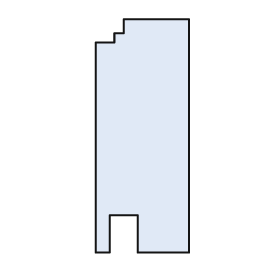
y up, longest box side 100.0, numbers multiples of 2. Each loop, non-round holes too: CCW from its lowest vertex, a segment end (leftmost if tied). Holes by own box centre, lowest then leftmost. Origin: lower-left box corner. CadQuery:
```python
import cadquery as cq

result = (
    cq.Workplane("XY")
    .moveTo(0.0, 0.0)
    .lineTo(6.0, 0.0)
    .lineTo(6.0, 16.0)
    .lineTo(18.0, 16.0)
    .lineTo(18.0, 0.0)
    .lineTo(40.0, 0.0)
    .lineTo(40.0, 100.0)
    .lineTo(12.0, 100.0)
    .lineTo(12.0, 94.0)
    .lineTo(8.0, 94.0)
    .lineTo(8.0, 90.0)
    .lineTo(0.0, 90.0)
    .close()
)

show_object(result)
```